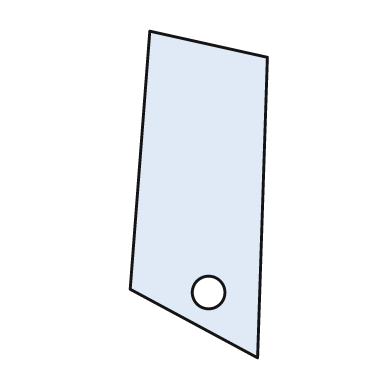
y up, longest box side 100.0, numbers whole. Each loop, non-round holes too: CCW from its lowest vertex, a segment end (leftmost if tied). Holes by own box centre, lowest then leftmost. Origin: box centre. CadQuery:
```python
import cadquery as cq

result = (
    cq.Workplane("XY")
    .moveTo(18.0, -50.0)
    .lineTo(21.0, 42.0)
    .lineTo(-15.0, 50.0)
    .lineTo(-21.0, -29.0)
    .close()
    .moveTo(3.0, -30.0)
    .circle(5.0)
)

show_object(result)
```